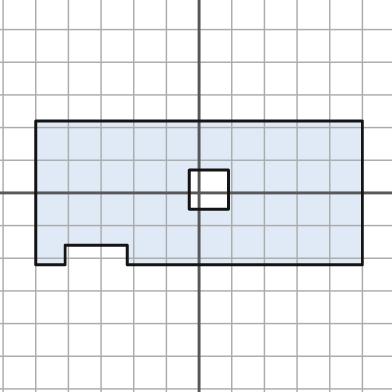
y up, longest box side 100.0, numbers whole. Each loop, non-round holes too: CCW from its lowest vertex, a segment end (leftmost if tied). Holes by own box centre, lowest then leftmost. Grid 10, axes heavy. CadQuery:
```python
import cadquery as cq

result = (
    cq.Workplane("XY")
    .moveTo(-50.0, -22.0)
    .lineTo(-41.0, -22.0)
    .lineTo(-41.0, -16.0)
    .lineTo(-22.0, -16.0)
    .lineTo(-22.0, -22.0)
    .lineTo(50.0, -22.0)
    .lineTo(50.0, 22.0)
    .lineTo(-50.0, 22.0)
    .close()
    .moveTo(-3.0, -5.0)
    .lineTo(9.0, -5.0)
    .lineTo(9.0, 7.0)
    .lineTo(-3.0, 7.0)
    .close()
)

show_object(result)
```